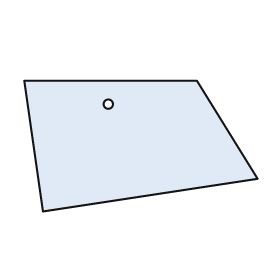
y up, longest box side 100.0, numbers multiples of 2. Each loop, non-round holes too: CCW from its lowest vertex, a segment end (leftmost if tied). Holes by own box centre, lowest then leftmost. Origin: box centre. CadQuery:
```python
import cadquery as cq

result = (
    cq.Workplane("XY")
    .moveTo(-42.0, -28.0)
    .lineTo(50.0, -14.0)
    .lineTo(24.0, 28.0)
    .lineTo(-50.0, 28.0)
    .close()
    .moveTo(-14.0, 18.0)
    .circle(2.0)
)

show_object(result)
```